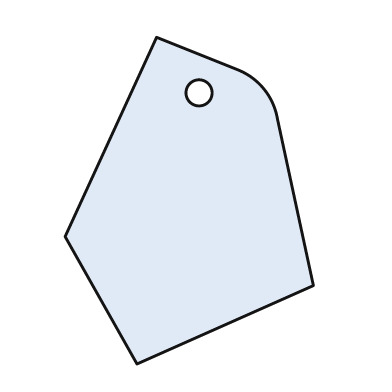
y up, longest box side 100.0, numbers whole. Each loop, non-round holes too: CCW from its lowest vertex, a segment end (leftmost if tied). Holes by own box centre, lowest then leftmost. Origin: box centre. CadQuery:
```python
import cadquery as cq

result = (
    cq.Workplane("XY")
    .moveTo(-16.0, -50.0)
    .lineTo(38.0, -26.0)
    .lineTo(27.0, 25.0)
    .threePointArc((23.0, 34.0), (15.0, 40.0))
    .lineTo(-10.0, 50.0)
    .lineTo(-38.0, -11.0)
    .close()
    .moveTo(3.0, 33.0)
    .circle(4.0)
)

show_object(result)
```